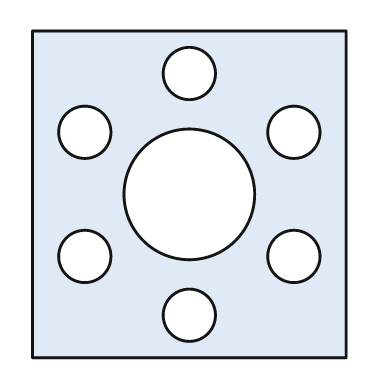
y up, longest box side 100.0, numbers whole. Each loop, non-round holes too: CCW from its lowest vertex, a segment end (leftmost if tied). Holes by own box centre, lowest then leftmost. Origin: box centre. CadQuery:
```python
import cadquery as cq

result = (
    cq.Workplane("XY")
    .moveTo(-48.0, -50.0)
    .lineTo(48.0, -50.0)
    .lineTo(48.0, 50.0)
    .lineTo(-48.0, 50.0)
    .close()
    .moveTo(0.0, -37.0)
    .circle(8.0)
    .moveTo(-32.0, -19.0)
    .circle(8.0)
    .moveTo(32.0, -19.0)
    .circle(8.0)
    .moveTo(0.0, 0.0)
    .circle(20.0)
    .moveTo(-32.0, 19.0)
    .circle(8.0)
    .moveTo(32.0, 19.0)
    .circle(8.0)
    .moveTo(0.0, 37.0)
    .circle(8.0)
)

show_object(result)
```